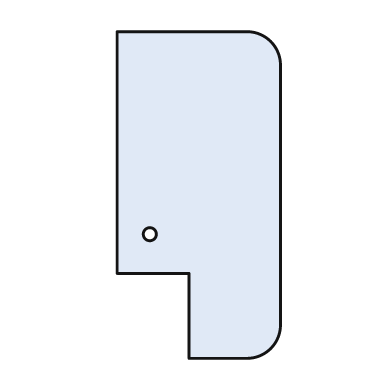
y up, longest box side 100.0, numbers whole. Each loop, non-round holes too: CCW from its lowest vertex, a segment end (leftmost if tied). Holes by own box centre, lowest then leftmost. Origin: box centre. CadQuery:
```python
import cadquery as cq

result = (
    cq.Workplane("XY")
    .moveTo(-3.0, -50.0)
    .lineTo(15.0, -50.0)
    .threePointArc((22.0, -47.0), (25.0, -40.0))
    .lineTo(25.0, 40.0)
    .threePointArc((22.0, 47.0), (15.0, 50.0))
    .lineTo(-25.0, 50.0)
    .lineTo(-25.0, -24.0)
    .lineTo(-3.0, -24.0)
    .close()
    .moveTo(-15.0, -12.0)
    .circle(2.0)
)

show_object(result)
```